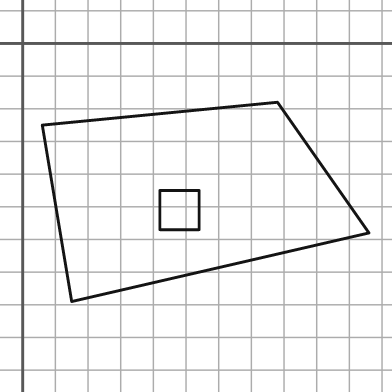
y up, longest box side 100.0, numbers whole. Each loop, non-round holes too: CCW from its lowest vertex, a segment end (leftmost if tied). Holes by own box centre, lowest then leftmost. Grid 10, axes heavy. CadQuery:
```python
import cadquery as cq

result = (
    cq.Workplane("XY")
    .moveTo(15.0, -79.0)
    .lineTo(106.0, -58.0)
    .lineTo(78.0, -18.0)
    .lineTo(6.0, -25.0)
    .close()
    .moveTo(42.0, -57.0)
    .lineTo(54.0, -57.0)
    .lineTo(54.0, -45.0)
    .lineTo(42.0, -45.0)
    .close()
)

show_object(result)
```